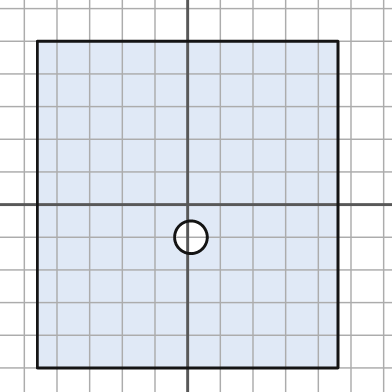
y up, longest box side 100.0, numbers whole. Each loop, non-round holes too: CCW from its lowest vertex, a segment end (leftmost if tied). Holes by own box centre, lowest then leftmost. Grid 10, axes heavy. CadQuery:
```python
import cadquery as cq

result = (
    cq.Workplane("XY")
    .moveTo(-46.0, -50.0)
    .lineTo(46.0, -50.0)
    .lineTo(46.0, 50.0)
    .lineTo(-46.0, 50.0)
    .close()
    .moveTo(1.0, -10.0)
    .circle(5.0)
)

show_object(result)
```